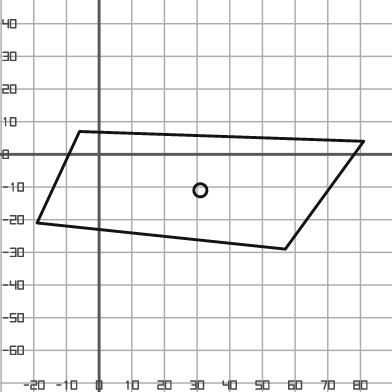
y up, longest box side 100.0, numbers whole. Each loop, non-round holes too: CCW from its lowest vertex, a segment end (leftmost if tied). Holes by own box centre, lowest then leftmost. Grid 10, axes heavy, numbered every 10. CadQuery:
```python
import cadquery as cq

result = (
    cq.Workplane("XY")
    .moveTo(57.0, -29.0)
    .lineTo(81.0, 4.0)
    .lineTo(-6.0, 7.0)
    .lineTo(-19.0, -21.0)
    .close()
    .moveTo(31.0, -11.0)
    .circle(2.0)
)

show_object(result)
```